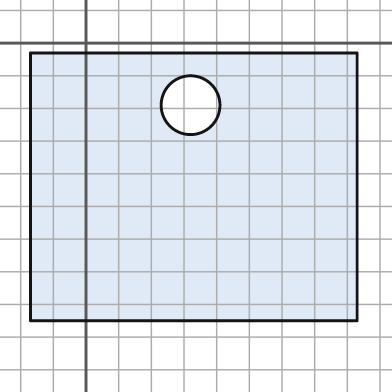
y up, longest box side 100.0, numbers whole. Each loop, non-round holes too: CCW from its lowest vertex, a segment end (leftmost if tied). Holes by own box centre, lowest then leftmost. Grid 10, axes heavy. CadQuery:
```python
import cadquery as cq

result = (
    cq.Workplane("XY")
    .moveTo(-17.0, -85.0)
    .lineTo(83.0, -85.0)
    .lineTo(83.0, -3.0)
    .lineTo(-17.0, -3.0)
    .close()
    .moveTo(32.0, -19.0)
    .circle(9.0)
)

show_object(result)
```